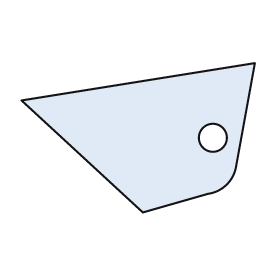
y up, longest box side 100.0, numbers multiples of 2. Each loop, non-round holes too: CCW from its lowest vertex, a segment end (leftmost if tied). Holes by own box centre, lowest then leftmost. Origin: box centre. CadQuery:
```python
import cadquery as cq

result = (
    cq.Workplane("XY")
    .moveTo(2.0, -32.0)
    .lineTo(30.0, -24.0)
    .threePointArc((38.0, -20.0), (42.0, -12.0))
    .lineTo(50.0, 32.0)
    .lineTo(-50.0, 16.0)
    .close()
    .moveTo(32.0, 0.0)
    .circle(6.0)
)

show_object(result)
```